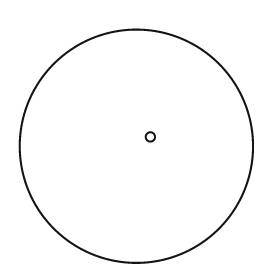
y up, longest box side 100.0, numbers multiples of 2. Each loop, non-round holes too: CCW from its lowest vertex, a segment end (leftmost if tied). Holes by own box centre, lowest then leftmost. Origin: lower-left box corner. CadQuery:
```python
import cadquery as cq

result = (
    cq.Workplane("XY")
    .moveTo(50.0, 50.0)
    .circle(50.0)
    .moveTo(56.0, 54.0)
    .circle(2.0)
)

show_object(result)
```